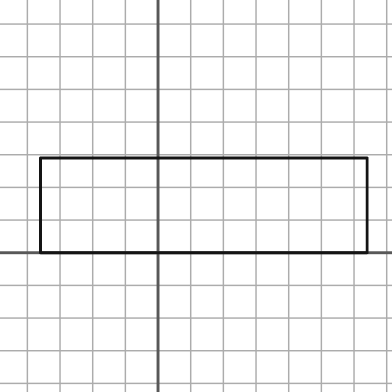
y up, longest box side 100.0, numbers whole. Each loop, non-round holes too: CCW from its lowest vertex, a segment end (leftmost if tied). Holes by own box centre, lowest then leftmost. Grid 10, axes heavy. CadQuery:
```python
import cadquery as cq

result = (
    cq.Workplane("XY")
    .moveTo(-36.0, 0.0)
    .lineTo(64.0, 0.0)
    .lineTo(64.0, 29.0)
    .lineTo(-36.0, 29.0)
    .close()
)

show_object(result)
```